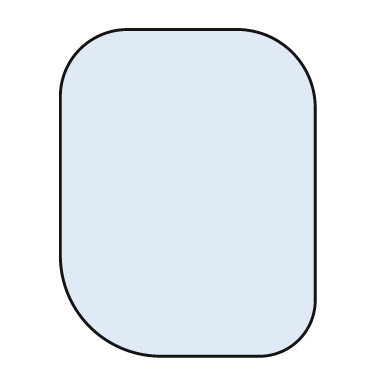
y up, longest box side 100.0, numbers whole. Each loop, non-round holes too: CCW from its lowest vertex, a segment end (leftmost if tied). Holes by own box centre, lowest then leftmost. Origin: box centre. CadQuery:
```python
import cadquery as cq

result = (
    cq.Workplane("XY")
    .moveTo(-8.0, -50.0)
    .lineTo(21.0, -50.0)
    .threePointArc((34.0, -45.0), (39.0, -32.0))
    .lineTo(39.0, 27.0)
    .threePointArc((32.0, 43.0), (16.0, 50.0))
    .lineTo(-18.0, 50.0)
    .threePointArc((-33.0, 44.0), (-39.0, 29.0))
    .lineTo(-39.0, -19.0)
    .threePointArc((-30.0, -41.0), (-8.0, -50.0))
    .close()
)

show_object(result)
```